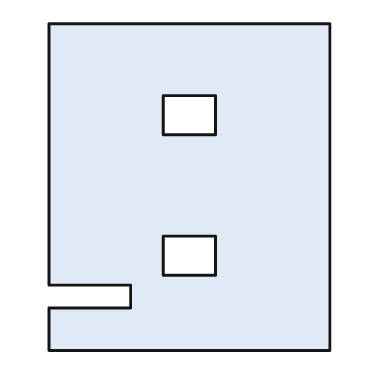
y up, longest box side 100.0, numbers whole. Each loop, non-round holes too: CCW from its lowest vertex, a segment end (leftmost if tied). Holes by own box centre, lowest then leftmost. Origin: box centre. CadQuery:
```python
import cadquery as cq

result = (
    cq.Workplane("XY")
    .moveTo(-43.0, -50.0)
    .lineTo(43.0, -50.0)
    .lineTo(43.0, 50.0)
    .lineTo(-43.0, 50.0)
    .lineTo(-43.0, -30.0)
    .lineTo(-18.0, -30.0)
    .lineTo(-18.0, -37.0)
    .lineTo(-43.0, -37.0)
    .close()
    .moveTo(-8.0, -27.0)
    .lineTo(8.0, -27.0)
    .lineTo(8.0, -15.0)
    .lineTo(-8.0, -15.0)
    .close()
    .moveTo(-8.0, 16.0)
    .lineTo(8.0, 16.0)
    .lineTo(8.0, 28.0)
    .lineTo(-8.0, 28.0)
    .close()
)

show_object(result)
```